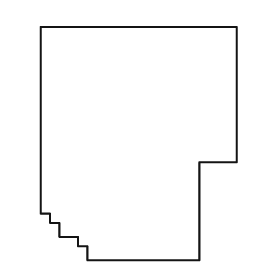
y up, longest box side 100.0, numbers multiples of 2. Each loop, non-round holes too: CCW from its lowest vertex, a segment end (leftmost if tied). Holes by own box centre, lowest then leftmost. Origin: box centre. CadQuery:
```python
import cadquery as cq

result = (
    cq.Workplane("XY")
    .moveTo(-22.0, -50.0)
    .lineTo(26.0, -50.0)
    .lineTo(26.0, -8.0)
    .lineTo(42.0, -8.0)
    .lineTo(42.0, 50.0)
    .lineTo(-42.0, 50.0)
    .lineTo(-42.0, -30.0)
    .lineTo(-38.0, -30.0)
    .lineTo(-38.0, -34.0)
    .lineTo(-34.0, -34.0)
    .lineTo(-34.0, -40.0)
    .lineTo(-26.0, -40.0)
    .lineTo(-26.0, -44.0)
    .lineTo(-22.0, -44.0)
    .close()
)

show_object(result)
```